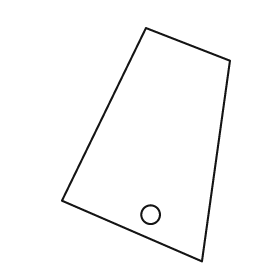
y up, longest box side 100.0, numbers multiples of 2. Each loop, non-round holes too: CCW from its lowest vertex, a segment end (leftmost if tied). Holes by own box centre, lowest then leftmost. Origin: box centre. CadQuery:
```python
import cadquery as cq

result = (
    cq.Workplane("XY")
    .moveTo(24.0, -50.0)
    .lineTo(36.0, 36.0)
    .lineTo(0.0, 50.0)
    .lineTo(-36.0, -24.0)
    .close()
    .moveTo(2.0, -30.0)
    .circle(4.0)
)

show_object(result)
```